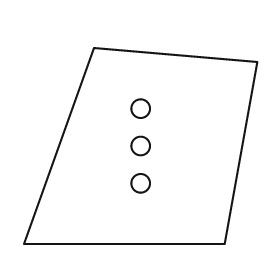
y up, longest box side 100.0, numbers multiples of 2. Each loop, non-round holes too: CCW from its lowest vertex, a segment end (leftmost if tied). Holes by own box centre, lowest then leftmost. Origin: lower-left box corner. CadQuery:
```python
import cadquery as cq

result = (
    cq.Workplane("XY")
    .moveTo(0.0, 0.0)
    .lineTo(86.0, 0.0)
    .lineTo(100.0, 78.0)
    .lineTo(30.0, 84.0)
    .close()
    .moveTo(50.0, 26.0)
    .circle(4.0)
    .moveTo(50.0, 42.0)
    .circle(4.0)
    .moveTo(50.0, 58.0)
    .circle(4.0)
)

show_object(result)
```